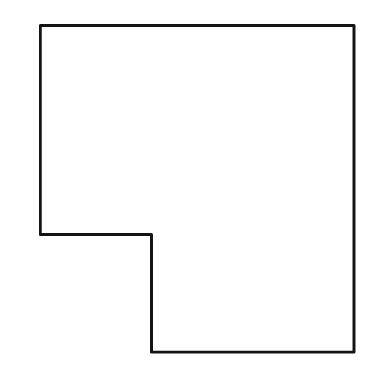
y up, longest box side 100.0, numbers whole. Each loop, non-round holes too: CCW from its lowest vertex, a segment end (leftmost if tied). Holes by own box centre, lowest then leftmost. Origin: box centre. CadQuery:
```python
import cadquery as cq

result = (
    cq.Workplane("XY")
    .moveTo(-14.0, -50.0)
    .lineTo(48.0, -50.0)
    .lineTo(48.0, 50.0)
    .lineTo(-48.0, 50.0)
    .lineTo(-48.0, -14.0)
    .lineTo(-14.0, -14.0)
    .close()
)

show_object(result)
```